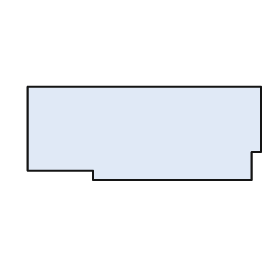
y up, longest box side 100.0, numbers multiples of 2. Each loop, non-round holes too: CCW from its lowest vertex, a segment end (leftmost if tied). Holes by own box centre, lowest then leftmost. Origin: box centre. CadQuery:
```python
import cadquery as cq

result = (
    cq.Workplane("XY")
    .moveTo(-22.0, -20.0)
    .lineTo(46.0, -20.0)
    .lineTo(46.0, -8.0)
    .lineTo(50.0, -8.0)
    .lineTo(50.0, 20.0)
    .lineTo(-50.0, 20.0)
    .lineTo(-50.0, -16.0)
    .lineTo(-22.0, -16.0)
    .close()
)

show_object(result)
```